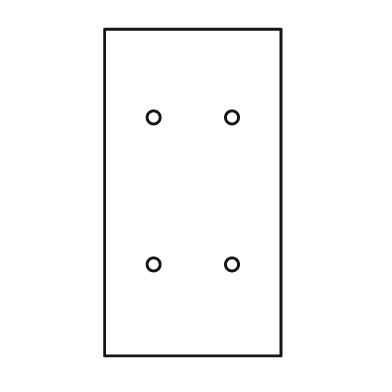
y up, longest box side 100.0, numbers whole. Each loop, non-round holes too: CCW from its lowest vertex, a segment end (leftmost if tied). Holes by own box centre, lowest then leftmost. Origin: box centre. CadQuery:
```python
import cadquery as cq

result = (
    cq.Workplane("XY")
    .moveTo(-27.0, -50.0)
    .lineTo(27.0, -50.0)
    .lineTo(27.0, 50.0)
    .lineTo(-27.0, 50.0)
    .close()
    .moveTo(-12.0, -22.0)
    .circle(2.0)
    .moveTo(12.0, -22.0)
    .circle(2.0)
    .moveTo(-12.0, 23.0)
    .circle(2.0)
    .moveTo(12.0, 23.0)
    .circle(2.0)
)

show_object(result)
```